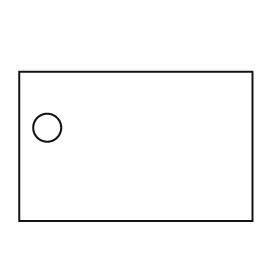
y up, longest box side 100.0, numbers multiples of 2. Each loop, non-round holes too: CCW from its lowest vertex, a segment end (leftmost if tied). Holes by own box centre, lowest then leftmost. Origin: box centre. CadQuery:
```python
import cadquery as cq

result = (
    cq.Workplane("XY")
    .moveTo(-50.0, -32.0)
    .lineTo(50.0, -32.0)
    .lineTo(50.0, 32.0)
    .lineTo(-50.0, 32.0)
    .close()
    .moveTo(-38.0, 8.0)
    .circle(6.0)
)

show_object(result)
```